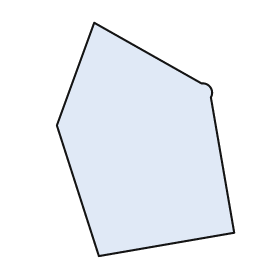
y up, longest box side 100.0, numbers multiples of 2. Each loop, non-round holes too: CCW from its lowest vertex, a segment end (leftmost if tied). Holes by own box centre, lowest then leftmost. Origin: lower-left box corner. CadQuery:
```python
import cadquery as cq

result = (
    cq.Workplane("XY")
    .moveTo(18.0, 0.0)
    .lineTo(76.0, 10.0)
    .lineTo(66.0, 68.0)
    .threePointArc((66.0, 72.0), (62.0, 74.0))
    .lineTo(16.0, 100.0)
    .lineTo(0.0, 56.0)
    .close()
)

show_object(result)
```